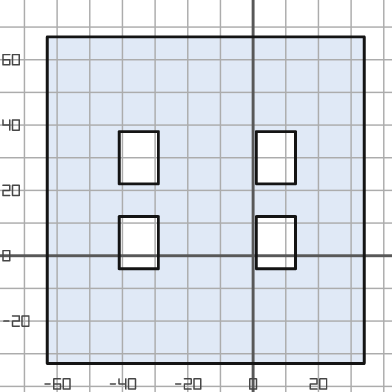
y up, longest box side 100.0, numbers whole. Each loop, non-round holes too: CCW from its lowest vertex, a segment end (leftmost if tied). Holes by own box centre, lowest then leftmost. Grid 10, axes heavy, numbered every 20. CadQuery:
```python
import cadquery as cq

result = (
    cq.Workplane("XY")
    .moveTo(-63.0, -33.0)
    .lineTo(34.0, -33.0)
    .lineTo(34.0, 67.0)
    .lineTo(-63.0, 67.0)
    .close()
    .moveTo(-41.0, -4.0)
    .lineTo(-29.0, -4.0)
    .lineTo(-29.0, 12.0)
    .lineTo(-41.0, 12.0)
    .close()
    .moveTo(1.0, -4.0)
    .lineTo(13.0, -4.0)
    .lineTo(13.0, 12.0)
    .lineTo(1.0, 12.0)
    .close()
    .moveTo(-41.0, 22.0)
    .lineTo(-29.0, 22.0)
    .lineTo(-29.0, 38.0)
    .lineTo(-41.0, 38.0)
    .close()
    .moveTo(1.0, 22.0)
    .lineTo(13.0, 22.0)
    .lineTo(13.0, 38.0)
    .lineTo(1.0, 38.0)
    .close()
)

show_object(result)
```